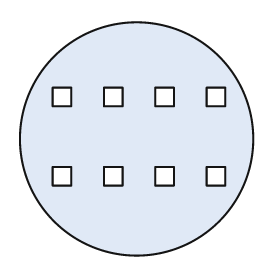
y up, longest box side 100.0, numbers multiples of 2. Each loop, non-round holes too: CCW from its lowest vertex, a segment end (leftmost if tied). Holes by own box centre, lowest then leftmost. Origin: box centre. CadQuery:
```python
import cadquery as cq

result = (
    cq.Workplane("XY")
    .moveTo(0.0, 0.0)
    .circle(50.0)
    .moveTo(-36.0, -20.0)
    .lineTo(-28.0, -20.0)
    .lineTo(-28.0, -12.0)
    .lineTo(-36.0, -12.0)
    .close()
    .moveTo(-14.0, -20.0)
    .lineTo(-6.0, -20.0)
    .lineTo(-6.0, -12.0)
    .lineTo(-14.0, -12.0)
    .close()
    .moveTo(8.0, -20.0)
    .lineTo(16.0, -20.0)
    .lineTo(16.0, -12.0)
    .lineTo(8.0, -12.0)
    .close()
    .moveTo(30.0, -20.0)
    .lineTo(38.0, -20.0)
    .lineTo(38.0, -12.0)
    .lineTo(30.0, -12.0)
    .close()
    .moveTo(-36.0, 14.0)
    .lineTo(-28.0, 14.0)
    .lineTo(-28.0, 22.0)
    .lineTo(-36.0, 22.0)
    .close()
    .moveTo(-14.0, 14.0)
    .lineTo(-6.0, 14.0)
    .lineTo(-6.0, 22.0)
    .lineTo(-14.0, 22.0)
    .close()
    .moveTo(8.0, 14.0)
    .lineTo(16.0, 14.0)
    .lineTo(16.0, 22.0)
    .lineTo(8.0, 22.0)
    .close()
    .moveTo(30.0, 14.0)
    .lineTo(38.0, 14.0)
    .lineTo(38.0, 22.0)
    .lineTo(30.0, 22.0)
    .close()
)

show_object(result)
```